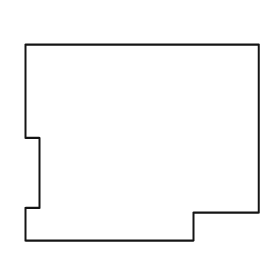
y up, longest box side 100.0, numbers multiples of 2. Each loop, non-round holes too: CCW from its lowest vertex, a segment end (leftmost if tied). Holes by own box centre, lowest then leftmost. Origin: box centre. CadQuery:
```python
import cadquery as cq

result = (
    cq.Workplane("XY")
    .moveTo(-50.0, -42.0)
    .lineTo(22.0, -42.0)
    .lineTo(22.0, -30.0)
    .lineTo(50.0, -30.0)
    .lineTo(50.0, 42.0)
    .lineTo(-50.0, 42.0)
    .lineTo(-50.0, 2.0)
    .lineTo(-44.0, 2.0)
    .lineTo(-44.0, -28.0)
    .lineTo(-50.0, -28.0)
    .close()
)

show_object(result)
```